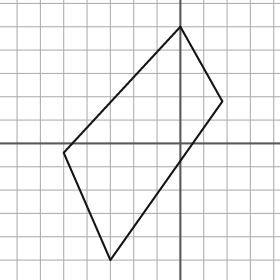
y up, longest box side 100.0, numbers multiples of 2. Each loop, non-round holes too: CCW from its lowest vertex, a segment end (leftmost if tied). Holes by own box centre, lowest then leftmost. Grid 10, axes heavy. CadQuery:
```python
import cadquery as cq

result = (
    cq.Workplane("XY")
    .moveTo(-30.0, -50.0)
    .lineTo(18.0, 18.0)
    .lineTo(0.0, 50.0)
    .lineTo(-50.0, -4.0)
    .close()
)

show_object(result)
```